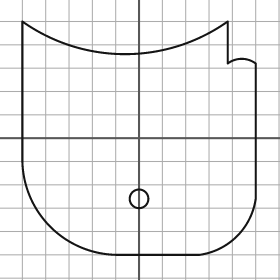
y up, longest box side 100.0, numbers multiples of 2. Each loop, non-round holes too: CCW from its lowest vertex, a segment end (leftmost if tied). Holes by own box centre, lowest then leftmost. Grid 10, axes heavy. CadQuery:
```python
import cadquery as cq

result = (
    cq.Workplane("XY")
    .moveTo(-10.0, -50.0)
    .lineTo(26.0, -50.0)
    .threePointArc((42.0, -42.0), (50.0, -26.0))
    .lineTo(50.0, 32.0)
    .threePointArc((44.0, 34.0), (38.0, 32.0))
    .lineTo(38.0, 50.0)
    .threePointArc((-6.0, 36.0), (-50.0, 50.0))
    .lineTo(-50.0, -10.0)
    .threePointArc((-38.0, -38.0), (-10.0, -50.0))
    .close()
    .moveTo(0.0, -26.0)
    .circle(4.0)
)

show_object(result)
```